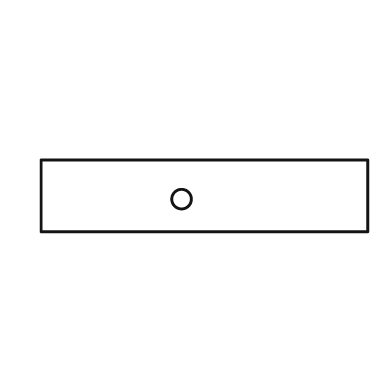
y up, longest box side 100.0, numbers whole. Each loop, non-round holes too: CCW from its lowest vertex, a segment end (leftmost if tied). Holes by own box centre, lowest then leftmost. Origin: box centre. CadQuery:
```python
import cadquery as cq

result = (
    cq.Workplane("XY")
    .moveTo(-50.0, -11.0)
    .lineTo(50.0, -11.0)
    .lineTo(50.0, 11.0)
    .lineTo(-50.0, 11.0)
    .close()
    .moveTo(-7.0, -1.0)
    .circle(3.0)
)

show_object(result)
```